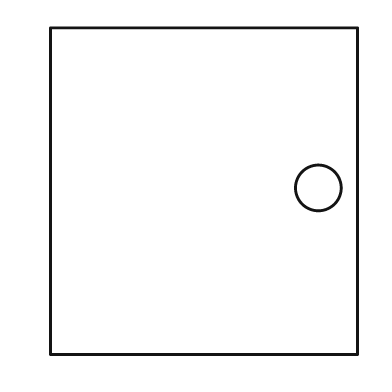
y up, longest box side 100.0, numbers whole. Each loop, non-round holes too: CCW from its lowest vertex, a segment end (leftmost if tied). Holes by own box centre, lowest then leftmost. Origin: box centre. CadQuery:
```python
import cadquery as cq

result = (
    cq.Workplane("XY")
    .moveTo(-47.0, -50.0)
    .lineTo(47.0, -50.0)
    .lineTo(47.0, 50.0)
    .lineTo(-47.0, 50.0)
    .close()
    .moveTo(35.0, 1.0)
    .circle(7.0)
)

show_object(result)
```